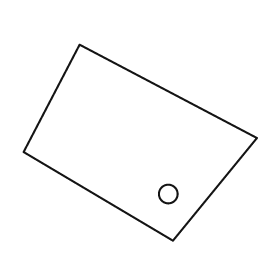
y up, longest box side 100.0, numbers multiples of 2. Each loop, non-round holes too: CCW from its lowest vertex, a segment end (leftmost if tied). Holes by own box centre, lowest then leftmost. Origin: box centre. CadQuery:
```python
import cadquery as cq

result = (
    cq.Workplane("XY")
    .moveTo(14.0, -42.0)
    .lineTo(50.0, 2.0)
    .lineTo(-26.0, 42.0)
    .lineTo(-50.0, -4.0)
    .close()
    .moveTo(12.0, -22.0)
    .circle(4.0)
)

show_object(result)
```